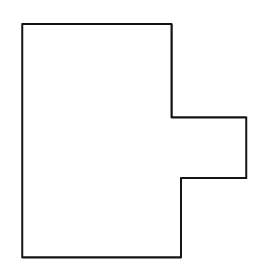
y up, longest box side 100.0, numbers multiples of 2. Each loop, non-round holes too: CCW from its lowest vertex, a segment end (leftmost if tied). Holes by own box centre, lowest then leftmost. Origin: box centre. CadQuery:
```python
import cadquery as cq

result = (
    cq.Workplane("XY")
    .moveTo(-48.0, -50.0)
    .lineTo(20.0, -50.0)
    .lineTo(20.0, -16.0)
    .lineTo(48.0, -16.0)
    .lineTo(48.0, 10.0)
    .lineTo(16.0, 10.0)
    .lineTo(16.0, 50.0)
    .lineTo(-48.0, 50.0)
    .close()
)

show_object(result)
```